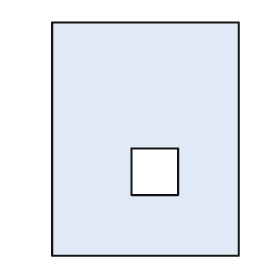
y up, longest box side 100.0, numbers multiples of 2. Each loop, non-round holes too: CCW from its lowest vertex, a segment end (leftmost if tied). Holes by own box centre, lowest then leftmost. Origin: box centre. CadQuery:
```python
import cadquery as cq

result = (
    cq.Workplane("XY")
    .moveTo(-40.0, -50.0)
    .lineTo(40.0, -50.0)
    .lineTo(40.0, 50.0)
    .lineTo(-40.0, 50.0)
    .close()
    .moveTo(-6.0, -24.0)
    .lineTo(14.0, -24.0)
    .lineTo(14.0, -4.0)
    .lineTo(-6.0, -4.0)
    .close()
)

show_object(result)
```